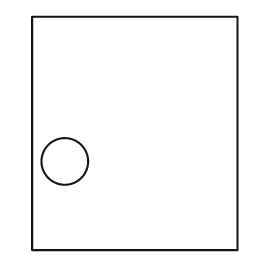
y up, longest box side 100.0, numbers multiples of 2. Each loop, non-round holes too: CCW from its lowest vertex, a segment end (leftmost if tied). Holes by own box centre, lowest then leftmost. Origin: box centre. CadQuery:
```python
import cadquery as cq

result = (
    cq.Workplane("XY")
    .moveTo(-44.0, -50.0)
    .lineTo(44.0, -50.0)
    .lineTo(44.0, 50.0)
    .lineTo(-44.0, 50.0)
    .close()
    .moveTo(-30.0, -12.0)
    .circle(10.0)
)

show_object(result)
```